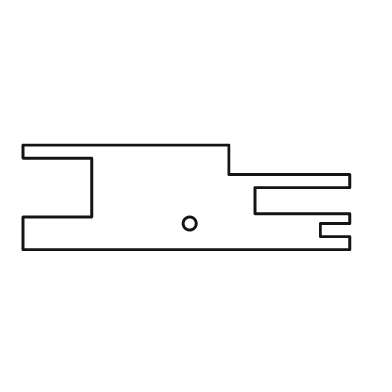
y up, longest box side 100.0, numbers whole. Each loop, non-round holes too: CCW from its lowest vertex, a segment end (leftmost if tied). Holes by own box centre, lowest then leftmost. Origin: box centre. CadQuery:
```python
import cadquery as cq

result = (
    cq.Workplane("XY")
    .moveTo(-50.0, -16.0)
    .lineTo(50.0, -16.0)
    .lineTo(50.0, -12.0)
    .lineTo(41.0, -12.0)
    .lineTo(41.0, -8.0)
    .lineTo(50.0, -8.0)
    .lineTo(50.0, -5.0)
    .lineTo(21.0, -5.0)
    .lineTo(21.0, 3.0)
    .lineTo(50.0, 3.0)
    .lineTo(50.0, 7.0)
    .lineTo(13.0, 7.0)
    .lineTo(13.0, 16.0)
    .lineTo(-50.0, 16.0)
    .lineTo(-50.0, 12.0)
    .lineTo(-29.0, 12.0)
    .lineTo(-29.0, -6.0)
    .lineTo(-50.0, -6.0)
    .close()
    .moveTo(1.0, -8.0)
    .circle(2.0)
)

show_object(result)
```